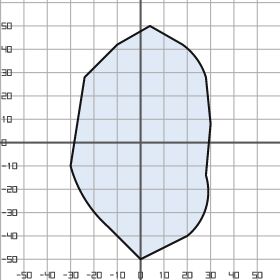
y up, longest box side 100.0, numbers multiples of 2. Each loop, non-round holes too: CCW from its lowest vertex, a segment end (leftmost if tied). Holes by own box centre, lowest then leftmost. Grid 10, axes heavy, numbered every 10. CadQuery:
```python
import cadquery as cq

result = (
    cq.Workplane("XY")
    .moveTo(0.0, -50.0)
    .lineTo(20.0, -40.0)
    .threePointArc((28.0, -28.0), (28.0, -14.0))
    .lineTo(30.0, 8.0)
    .lineTo(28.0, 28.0)
    .threePointArc((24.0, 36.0), (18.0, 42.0))
    .lineTo(4.0, 50.0)
    .lineTo(-10.0, 42.0)
    .lineTo(-24.0, 28.0)
    .lineTo(-30.0, -10.0)
    .threePointArc((-24.0, -24.0), (-14.0, -36.0))
    .close()
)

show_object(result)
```